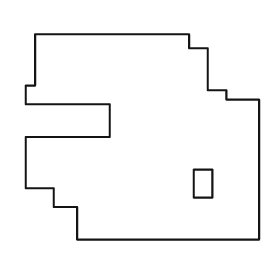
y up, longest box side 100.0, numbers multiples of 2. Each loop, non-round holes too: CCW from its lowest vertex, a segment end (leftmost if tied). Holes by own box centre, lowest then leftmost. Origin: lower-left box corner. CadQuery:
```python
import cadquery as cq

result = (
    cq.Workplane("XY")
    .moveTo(22.0, 0.0)
    .lineTo(100.0, 0.0)
    .lineTo(100.0, 60.0)
    .lineTo(86.0, 60.0)
    .lineTo(86.0, 64.0)
    .lineTo(78.0, 64.0)
    .lineTo(78.0, 82.0)
    .lineTo(70.0, 82.0)
    .lineTo(70.0, 88.0)
    .lineTo(4.0, 88.0)
    .lineTo(4.0, 66.0)
    .lineTo(0.0, 66.0)
    .lineTo(0.0, 58.0)
    .lineTo(36.0, 58.0)
    .lineTo(36.0, 44.0)
    .lineTo(0.0, 44.0)
    .lineTo(0.0, 22.0)
    .lineTo(12.0, 22.0)
    .lineTo(12.0, 14.0)
    .lineTo(22.0, 14.0)
    .close()
    .moveTo(72.0, 18.0)
    .lineTo(80.0, 18.0)
    .lineTo(80.0, 30.0)
    .lineTo(72.0, 30.0)
    .close()
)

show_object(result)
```